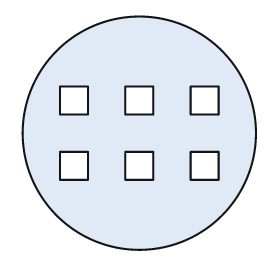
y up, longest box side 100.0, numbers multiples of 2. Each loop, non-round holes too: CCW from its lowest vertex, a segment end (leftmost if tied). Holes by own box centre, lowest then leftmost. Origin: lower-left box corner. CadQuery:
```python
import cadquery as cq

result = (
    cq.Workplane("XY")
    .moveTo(50.0, 50.0)
    .circle(50.0)
    .moveTo(16.0, 30.0)
    .lineTo(28.0, 30.0)
    .lineTo(28.0, 42.0)
    .lineTo(16.0, 42.0)
    .close()
    .moveTo(44.0, 30.0)
    .lineTo(56.0, 30.0)
    .lineTo(56.0, 42.0)
    .lineTo(44.0, 42.0)
    .close()
    .moveTo(72.0, 30.0)
    .lineTo(84.0, 30.0)
    .lineTo(84.0, 42.0)
    .lineTo(72.0, 42.0)
    .close()
    .moveTo(16.0, 58.0)
    .lineTo(28.0, 58.0)
    .lineTo(28.0, 70.0)
    .lineTo(16.0, 70.0)
    .close()
    .moveTo(44.0, 58.0)
    .lineTo(56.0, 58.0)
    .lineTo(56.0, 70.0)
    .lineTo(44.0, 70.0)
    .close()
    .moveTo(72.0, 58.0)
    .lineTo(84.0, 58.0)
    .lineTo(84.0, 70.0)
    .lineTo(72.0, 70.0)
    .close()
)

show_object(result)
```